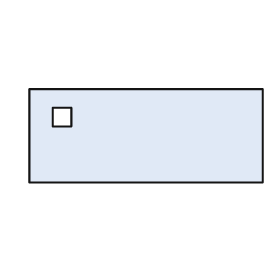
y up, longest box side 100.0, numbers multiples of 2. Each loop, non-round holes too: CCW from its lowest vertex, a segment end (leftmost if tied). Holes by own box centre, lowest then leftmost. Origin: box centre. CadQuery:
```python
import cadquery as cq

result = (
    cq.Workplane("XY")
    .moveTo(-50.0, -20.0)
    .lineTo(50.0, -20.0)
    .lineTo(50.0, 20.0)
    .lineTo(-50.0, 20.0)
    .close()
    .moveTo(-40.0, 4.0)
    .lineTo(-32.0, 4.0)
    .lineTo(-32.0, 12.0)
    .lineTo(-40.0, 12.0)
    .close()
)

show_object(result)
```